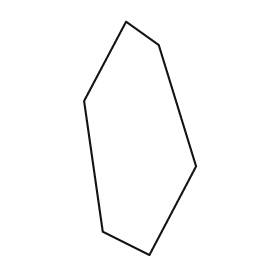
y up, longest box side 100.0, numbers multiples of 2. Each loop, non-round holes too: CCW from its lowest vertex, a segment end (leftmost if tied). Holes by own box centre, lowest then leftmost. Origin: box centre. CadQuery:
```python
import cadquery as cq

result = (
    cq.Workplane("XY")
    .moveTo(4.0, -50.0)
    .lineTo(24.0, -12.0)
    .lineTo(8.0, 40.0)
    .lineTo(-6.0, 50.0)
    .lineTo(-24.0, 16.0)
    .lineTo(-16.0, -40.0)
    .close()
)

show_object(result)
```